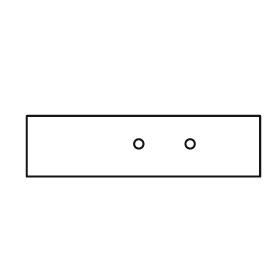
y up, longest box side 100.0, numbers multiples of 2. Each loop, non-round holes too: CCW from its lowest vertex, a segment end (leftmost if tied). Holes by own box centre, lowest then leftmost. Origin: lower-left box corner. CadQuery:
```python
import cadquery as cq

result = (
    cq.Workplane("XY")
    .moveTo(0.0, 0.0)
    .lineTo(100.0, 0.0)
    .lineTo(100.0, 26.0)
    .lineTo(0.0, 26.0)
    .close()
    .moveTo(48.0, 14.0)
    .circle(2.0)
    .moveTo(70.0, 14.0)
    .circle(2.0)
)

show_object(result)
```